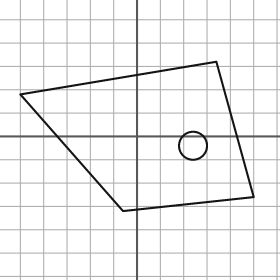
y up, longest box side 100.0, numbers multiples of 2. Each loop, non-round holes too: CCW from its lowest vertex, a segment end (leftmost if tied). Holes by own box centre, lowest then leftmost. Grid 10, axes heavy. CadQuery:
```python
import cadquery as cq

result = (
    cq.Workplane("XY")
    .moveTo(-6.0, -32.0)
    .lineTo(50.0, -26.0)
    .lineTo(34.0, 32.0)
    .lineTo(-50.0, 18.0)
    .close()
    .moveTo(24.0, -4.0)
    .circle(6.0)
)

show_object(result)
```